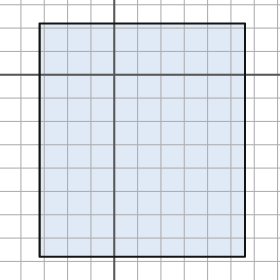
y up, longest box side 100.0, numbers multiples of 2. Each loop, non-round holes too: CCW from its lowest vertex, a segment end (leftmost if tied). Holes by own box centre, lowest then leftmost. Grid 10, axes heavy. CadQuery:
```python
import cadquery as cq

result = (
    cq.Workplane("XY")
    .moveTo(-32.0, -78.0)
    .lineTo(56.0, -78.0)
    .lineTo(56.0, 22.0)
    .lineTo(-32.0, 22.0)
    .close()
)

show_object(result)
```